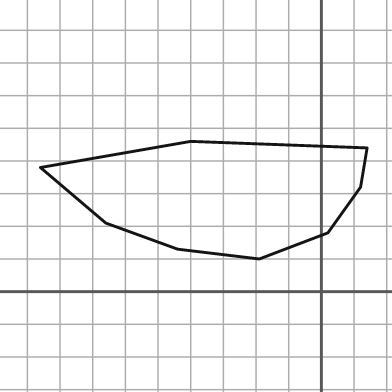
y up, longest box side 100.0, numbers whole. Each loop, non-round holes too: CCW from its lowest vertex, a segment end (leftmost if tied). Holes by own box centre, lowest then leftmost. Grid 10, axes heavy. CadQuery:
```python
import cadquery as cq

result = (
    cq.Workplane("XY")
    .moveTo(-19.0, 10.0)
    .lineTo(2.0, 18.0)
    .lineTo(12.0, 32.0)
    .lineTo(14.0, 44.0)
    .lineTo(-40.0, 46.0)
    .lineTo(-86.0, 38.0)
    .lineTo(-66.0, 21.0)
    .lineTo(-44.0, 13.0)
    .close()
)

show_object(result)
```